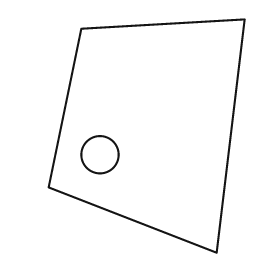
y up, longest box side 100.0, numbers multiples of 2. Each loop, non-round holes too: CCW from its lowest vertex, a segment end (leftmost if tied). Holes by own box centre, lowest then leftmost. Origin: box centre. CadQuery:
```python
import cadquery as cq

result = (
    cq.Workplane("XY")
    .moveTo(30.0, -50.0)
    .lineTo(42.0, 50.0)
    .lineTo(-28.0, 46.0)
    .lineTo(-42.0, -22.0)
    .close()
    .moveTo(-20.0, -8.0)
    .circle(8.0)
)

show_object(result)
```